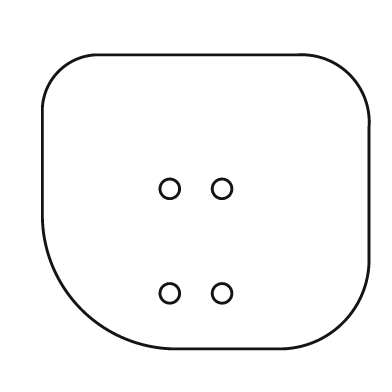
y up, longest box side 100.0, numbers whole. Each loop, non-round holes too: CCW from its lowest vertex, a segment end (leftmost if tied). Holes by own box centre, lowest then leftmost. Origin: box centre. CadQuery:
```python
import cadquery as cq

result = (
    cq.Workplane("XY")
    .moveTo(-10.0, -45.0)
    .lineTo(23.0, -45.0)
    .threePointArc((42.0, -37.0), (50.0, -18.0))
    .lineTo(50.0, 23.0)
    .threePointArc((44.0, 39.0), (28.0, 45.0))
    .lineTo(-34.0, 45.0)
    .threePointArc((-45.0, 40.0), (-50.0, 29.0))
    .lineTo(-50.0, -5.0)
    .threePointArc((-38.0, -33.0), (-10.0, -45.0))
    .close()
    .moveTo(-11.0, -28.0)
    .circle(3.0)
    .moveTo(5.0, -28.0)
    .circle(3.0)
    .moveTo(-11.0, 4.0)
    .circle(3.0)
    .moveTo(5.0, 4.0)
    .circle(3.0)
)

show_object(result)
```